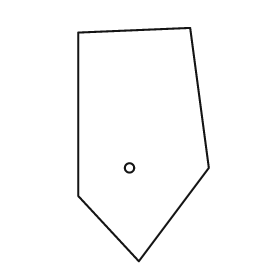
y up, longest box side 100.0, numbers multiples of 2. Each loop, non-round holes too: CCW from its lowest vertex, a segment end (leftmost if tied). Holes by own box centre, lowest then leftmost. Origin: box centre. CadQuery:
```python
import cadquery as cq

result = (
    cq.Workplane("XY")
    .moveTo(-2.0, -50.0)
    .lineTo(28.0, -10.0)
    .lineTo(20.0, 50.0)
    .lineTo(-28.0, 48.0)
    .lineTo(-28.0, -22.0)
    .close()
    .moveTo(-6.0, -10.0)
    .circle(2.0)
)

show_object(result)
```